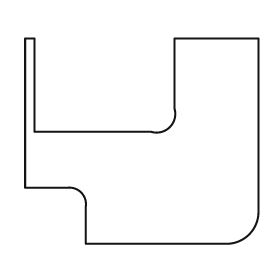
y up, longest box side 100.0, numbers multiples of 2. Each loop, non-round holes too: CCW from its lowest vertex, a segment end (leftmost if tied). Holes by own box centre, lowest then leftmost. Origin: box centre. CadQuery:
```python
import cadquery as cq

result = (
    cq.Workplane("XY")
    .moveTo(-24.0, -44.0)
    .lineTo(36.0, -44.0)
    .threePointArc((46.0, -40.0), (50.0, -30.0))
    .lineTo(50.0, 44.0)
    .lineTo(14.0, 44.0)
    .lineTo(14.0, 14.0)
    .threePointArc((12.0, 6.0), (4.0, 4.0))
    .lineTo(-46.0, 4.0)
    .lineTo(-46.0, 44.0)
    .lineTo(-50.0, 44.0)
    .lineTo(-50.0, -20.0)
    .lineTo(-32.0, -20.0)
    .threePointArc((-26.0, -22.0), (-24.0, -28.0))
    .close()
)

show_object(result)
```